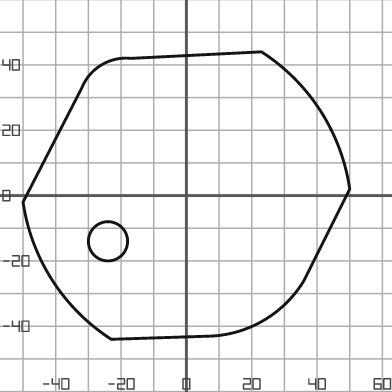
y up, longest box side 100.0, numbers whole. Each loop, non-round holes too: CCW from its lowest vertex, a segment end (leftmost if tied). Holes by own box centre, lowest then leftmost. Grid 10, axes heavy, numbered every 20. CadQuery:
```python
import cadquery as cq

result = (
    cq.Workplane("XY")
    .moveTo(-23.0, -44.0)
    .lineTo(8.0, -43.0)
    .threePointArc((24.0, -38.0), (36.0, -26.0))
    .lineTo(50.0, 2.0)
    .threePointArc((41.0, 26.0), (23.0, 44.0))
    .lineTo(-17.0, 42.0)
    .threePointArc((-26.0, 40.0), (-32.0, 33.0))
    .lineTo(-50.0, -2.0)
    .threePointArc((-41.0, -26.0), (-23.0, -44.0))
    .close()
    .moveTo(-24.0, -14.0)
    .circle(6.0)
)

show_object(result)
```